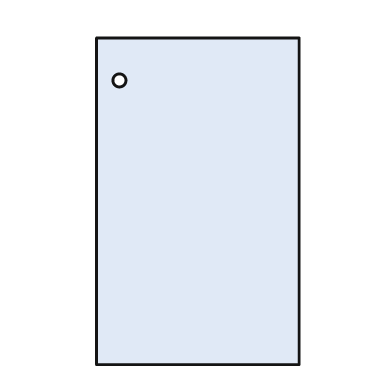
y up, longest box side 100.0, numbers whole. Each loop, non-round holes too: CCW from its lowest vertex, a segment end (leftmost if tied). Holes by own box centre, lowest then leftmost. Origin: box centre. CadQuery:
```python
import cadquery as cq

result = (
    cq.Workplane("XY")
    .moveTo(-31.0, -50.0)
    .lineTo(31.0, -50.0)
    .lineTo(31.0, 50.0)
    .lineTo(-31.0, 50.0)
    .close()
    .moveTo(-24.0, 37.0)
    .circle(2.0)
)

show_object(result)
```